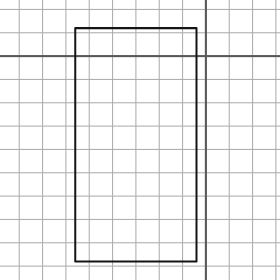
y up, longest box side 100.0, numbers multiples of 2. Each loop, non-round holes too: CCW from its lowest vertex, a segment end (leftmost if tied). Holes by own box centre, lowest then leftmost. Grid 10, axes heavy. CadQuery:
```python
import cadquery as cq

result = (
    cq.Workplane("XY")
    .moveTo(-56.0, -88.0)
    .lineTo(-4.0, -88.0)
    .lineTo(-4.0, 12.0)
    .lineTo(-56.0, 12.0)
    .close()
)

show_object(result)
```